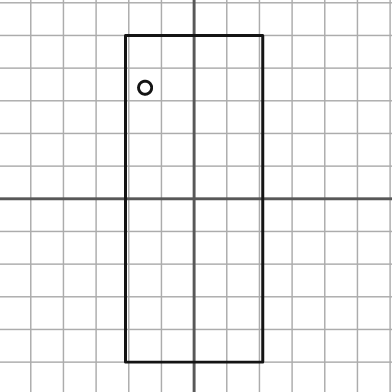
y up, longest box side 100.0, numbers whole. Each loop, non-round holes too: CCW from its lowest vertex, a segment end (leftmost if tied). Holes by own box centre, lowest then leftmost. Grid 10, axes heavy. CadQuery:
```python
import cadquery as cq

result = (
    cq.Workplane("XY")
    .moveTo(-21.0, -50.0)
    .lineTo(21.0, -50.0)
    .lineTo(21.0, 50.0)
    .lineTo(-21.0, 50.0)
    .close()
    .moveTo(-15.0, 34.0)
    .circle(2.0)
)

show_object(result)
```